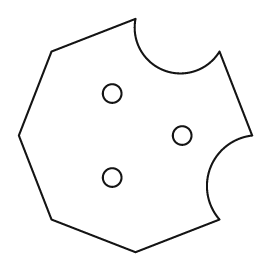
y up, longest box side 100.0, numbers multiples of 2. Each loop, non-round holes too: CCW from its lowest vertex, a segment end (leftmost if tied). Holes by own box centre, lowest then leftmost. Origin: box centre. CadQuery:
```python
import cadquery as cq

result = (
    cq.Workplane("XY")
    .moveTo(0.0, -50.0)
    .lineTo(36.0, -36.0)
    .threePointArc((32.0, -14.0), (50.0, 0.0))
    .lineTo(36.0, 36.0)
    .threePointArc((12.0, 28.0), (0.0, 50.0))
    .lineTo(-36.0, 36.0)
    .lineTo(-50.0, 0.0)
    .lineTo(-36.0, -36.0)
    .close()
    .moveTo(-10.0, -18.0)
    .circle(4.0)
    .moveTo(20.0, 0.0)
    .circle(4.0)
    .moveTo(-10.0, 18.0)
    .circle(4.0)
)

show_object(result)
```